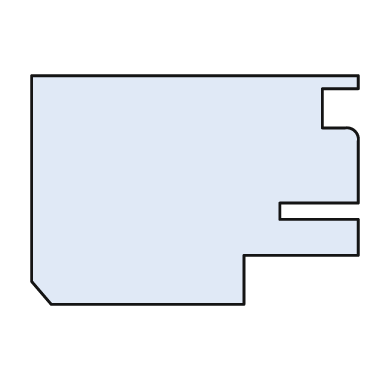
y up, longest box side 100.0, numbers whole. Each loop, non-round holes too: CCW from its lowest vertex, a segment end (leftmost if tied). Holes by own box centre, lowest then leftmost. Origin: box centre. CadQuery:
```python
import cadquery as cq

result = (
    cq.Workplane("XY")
    .moveTo(-44.0, -35.0)
    .lineTo(15.0, -35.0)
    .lineTo(15.0, -20.0)
    .lineTo(50.0, -20.0)
    .lineTo(50.0, -9.0)
    .lineTo(26.0, -9.0)
    .lineTo(26.0, -4.0)
    .lineTo(50.0, -4.0)
    .lineTo(50.0, 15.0)
    .threePointArc((49.0, 18.0), (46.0, 19.0))
    .lineTo(39.0, 19.0)
    .lineTo(39.0, 31.0)
    .lineTo(50.0, 31.0)
    .lineTo(50.0, 35.0)
    .lineTo(-50.0, 35.0)
    .lineTo(-50.0, -28.0)
    .close()
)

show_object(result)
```